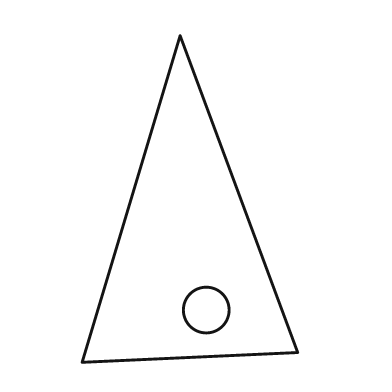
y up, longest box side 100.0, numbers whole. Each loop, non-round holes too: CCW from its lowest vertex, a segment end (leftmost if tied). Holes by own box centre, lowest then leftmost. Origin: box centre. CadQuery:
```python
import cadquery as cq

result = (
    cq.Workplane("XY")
    .moveTo(-33.0, -50.0)
    .lineTo(33.0, -47.0)
    .lineTo(-3.0, 50.0)
    .close()
    .moveTo(5.0, -34.0)
    .circle(7.0)
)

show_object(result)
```